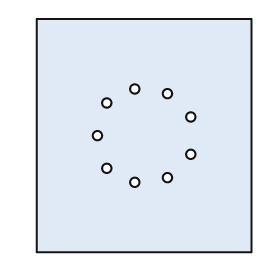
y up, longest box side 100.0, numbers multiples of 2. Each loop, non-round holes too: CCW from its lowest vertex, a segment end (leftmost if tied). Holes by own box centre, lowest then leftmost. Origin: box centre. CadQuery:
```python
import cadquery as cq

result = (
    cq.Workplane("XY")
    .moveTo(-46.0, -50.0)
    .lineTo(46.0, -50.0)
    .lineTo(46.0, 50.0)
    .lineTo(-46.0, 50.0)
    .close()
    .moveTo(-4.0, -20.0)
    .circle(2.0)
    .moveTo(10.0, -18.0)
    .circle(2.0)
    .moveTo(-16.0, -14.0)
    .circle(2.0)
    .moveTo(20.0, -8.0)
    .circle(2.0)
    .moveTo(-20.0, 0.0)
    .circle(2.0)
    .moveTo(20.0, 8.0)
    .circle(2.0)
    .moveTo(-16.0, 14.0)
    .circle(2.0)
    .moveTo(10.0, 18.0)
    .circle(2.0)
    .moveTo(-4.0, 20.0)
    .circle(2.0)
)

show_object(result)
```